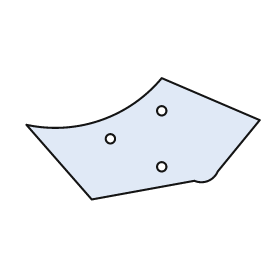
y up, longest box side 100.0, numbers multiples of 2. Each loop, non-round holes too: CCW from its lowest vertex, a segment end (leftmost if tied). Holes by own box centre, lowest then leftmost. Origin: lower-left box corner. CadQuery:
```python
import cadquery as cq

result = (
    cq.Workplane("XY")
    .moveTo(28.0, 0.0)
    .lineTo(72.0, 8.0)
    .threePointArc((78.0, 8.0), (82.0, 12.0))
    .lineTo(100.0, 34.0)
    .lineTo(58.0, 52.0)
    .threePointArc((32.0, 34.0), (0.0, 32.0))
    .close()
    .moveTo(58.0, 14.0)
    .circle(2.0)
    .moveTo(36.0, 26.0)
    .circle(2.0)
    .moveTo(58.0, 38.0)
    .circle(2.0)
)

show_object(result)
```